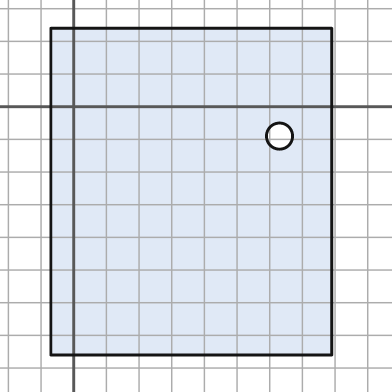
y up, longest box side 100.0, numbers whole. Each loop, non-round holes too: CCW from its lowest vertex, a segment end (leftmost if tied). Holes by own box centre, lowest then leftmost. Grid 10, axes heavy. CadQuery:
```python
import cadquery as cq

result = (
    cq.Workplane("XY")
    .moveTo(-7.0, -76.0)
    .lineTo(79.0, -76.0)
    .lineTo(79.0, 24.0)
    .lineTo(-7.0, 24.0)
    .close()
    .moveTo(63.0, -9.0)
    .circle(4.0)
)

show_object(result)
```